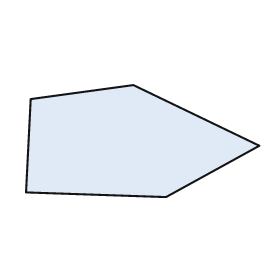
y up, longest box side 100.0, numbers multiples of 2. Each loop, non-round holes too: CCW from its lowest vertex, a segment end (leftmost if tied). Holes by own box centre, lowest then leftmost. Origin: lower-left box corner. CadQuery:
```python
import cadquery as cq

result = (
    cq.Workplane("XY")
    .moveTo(60.0, 0.0)
    .lineTo(100.0, 22.0)
    .lineTo(46.0, 48.0)
    .lineTo(2.0, 42.0)
    .lineTo(0.0, 2.0)
    .close()
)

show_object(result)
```